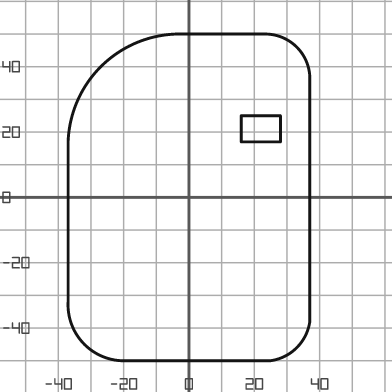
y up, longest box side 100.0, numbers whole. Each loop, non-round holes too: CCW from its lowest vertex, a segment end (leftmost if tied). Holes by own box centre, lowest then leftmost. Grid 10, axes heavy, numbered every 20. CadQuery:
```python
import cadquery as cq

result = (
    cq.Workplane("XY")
    .moveTo(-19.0, -50.0)
    .lineTo(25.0, -50.0)
    .threePointArc((33.0, -46.0), (37.0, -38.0))
    .lineTo(37.0, 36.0)
    .threePointArc((33.0, 46.0), (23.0, 50.0))
    .lineTo(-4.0, 50.0)
    .threePointArc((-27.0, 40.0), (-37.0, 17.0))
    .lineTo(-37.0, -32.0)
    .threePointArc((-32.0, -45.0), (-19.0, -50.0))
    .close()
    .moveTo(16.0, 17.0)
    .lineTo(28.0, 17.0)
    .lineTo(28.0, 25.0)
    .lineTo(16.0, 25.0)
    .close()
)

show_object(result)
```